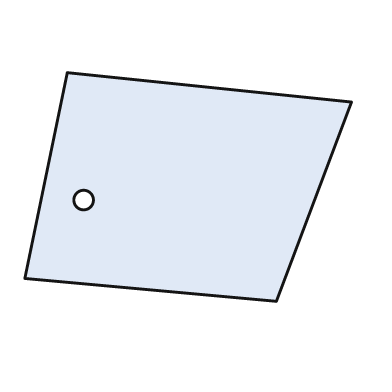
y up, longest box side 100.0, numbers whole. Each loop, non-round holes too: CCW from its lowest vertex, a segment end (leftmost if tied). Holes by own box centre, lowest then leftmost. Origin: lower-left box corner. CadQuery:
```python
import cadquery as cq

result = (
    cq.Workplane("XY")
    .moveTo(77.0, 0.0)
    .lineTo(100.0, 61.0)
    .lineTo(13.0, 70.0)
    .lineTo(0.0, 7.0)
    .close()
    .moveTo(18.0, 31.0)
    .circle(3.0)
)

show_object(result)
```